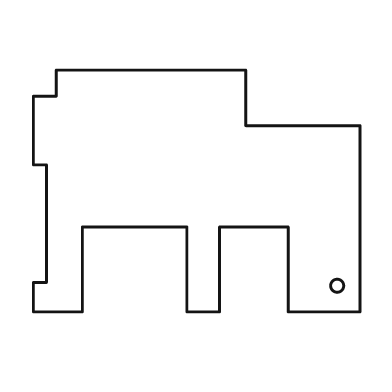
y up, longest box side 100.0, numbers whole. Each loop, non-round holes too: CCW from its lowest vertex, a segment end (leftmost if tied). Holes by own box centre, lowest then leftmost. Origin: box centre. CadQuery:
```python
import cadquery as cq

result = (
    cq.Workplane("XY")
    .moveTo(-50.0, -37.0)
    .lineTo(-35.0, -37.0)
    .lineTo(-35.0, -11.0)
    .lineTo(-3.0, -11.0)
    .lineTo(-3.0, -37.0)
    .lineTo(7.0, -37.0)
    .lineTo(7.0, -11.0)
    .lineTo(28.0, -11.0)
    .lineTo(28.0, -37.0)
    .lineTo(50.0, -37.0)
    .lineTo(50.0, 20.0)
    .lineTo(15.0, 20.0)
    .lineTo(15.0, 37.0)
    .lineTo(-43.0, 37.0)
    .lineTo(-43.0, 29.0)
    .lineTo(-50.0, 29.0)
    .lineTo(-50.0, 8.0)
    .lineTo(-46.0, 8.0)
    .lineTo(-46.0, -28.0)
    .lineTo(-50.0, -28.0)
    .close()
    .moveTo(43.0, -29.0)
    .circle(2.0)
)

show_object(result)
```